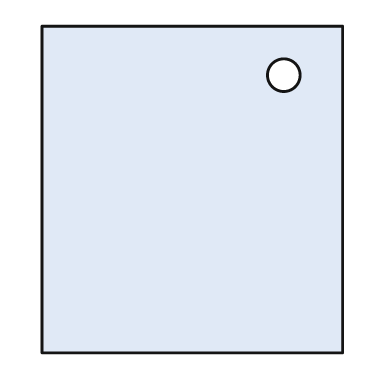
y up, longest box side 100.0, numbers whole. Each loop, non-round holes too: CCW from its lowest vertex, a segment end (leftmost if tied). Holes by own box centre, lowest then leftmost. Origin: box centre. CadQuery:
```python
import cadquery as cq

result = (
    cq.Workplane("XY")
    .moveTo(-46.0, -50.0)
    .lineTo(46.0, -50.0)
    .lineTo(46.0, 50.0)
    .lineTo(-46.0, 50.0)
    .close()
    .moveTo(28.0, 35.0)
    .circle(5.0)
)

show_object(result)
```